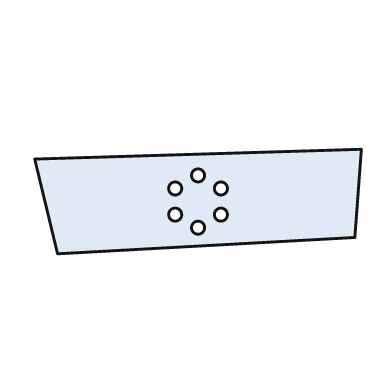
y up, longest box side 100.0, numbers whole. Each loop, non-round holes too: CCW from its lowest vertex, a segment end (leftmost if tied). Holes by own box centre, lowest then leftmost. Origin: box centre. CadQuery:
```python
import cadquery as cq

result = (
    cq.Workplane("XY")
    .moveTo(-43.0, -16.0)
    .lineTo(48.0, -11.0)
    .lineTo(50.0, 16.0)
    .lineTo(-50.0, 13.0)
    .close()
    .moveTo(0.0, -8.0)
    .circle(2.0)
    .moveTo(-7.0, -4.0)
    .circle(2.0)
    .moveTo(7.0, -4.0)
    .circle(2.0)
    .moveTo(-7.0, 4.0)
    .circle(2.0)
    .moveTo(7.0, 4.0)
    .circle(2.0)
    .moveTo(0.0, 8.0)
    .circle(2.0)
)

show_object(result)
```